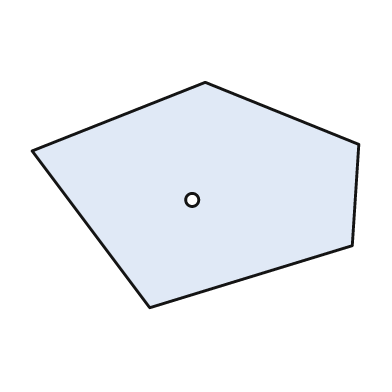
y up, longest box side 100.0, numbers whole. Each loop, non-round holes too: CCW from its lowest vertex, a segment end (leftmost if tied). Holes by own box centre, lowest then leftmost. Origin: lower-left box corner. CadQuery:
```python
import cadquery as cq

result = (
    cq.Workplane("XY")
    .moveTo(36.0, 0.0)
    .lineTo(98.0, 19.0)
    .lineTo(100.0, 50.0)
    .lineTo(53.0, 69.0)
    .lineTo(0.0, 48.0)
    .close()
    .moveTo(49.0, 33.0)
    .circle(2.0)
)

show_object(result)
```